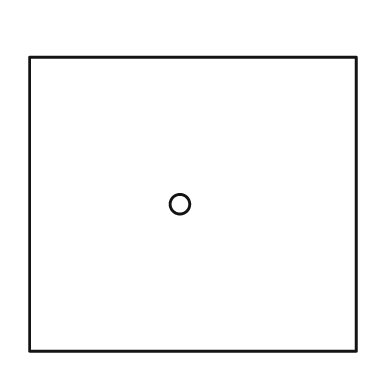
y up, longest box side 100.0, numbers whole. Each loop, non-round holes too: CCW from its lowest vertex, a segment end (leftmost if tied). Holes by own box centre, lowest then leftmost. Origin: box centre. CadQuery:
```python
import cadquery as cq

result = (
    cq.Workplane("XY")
    .moveTo(-50.0, -45.0)
    .lineTo(50.0, -45.0)
    .lineTo(50.0, 45.0)
    .lineTo(-50.0, 45.0)
    .close()
    .moveTo(-4.0, 0.0)
    .circle(3.0)
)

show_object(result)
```